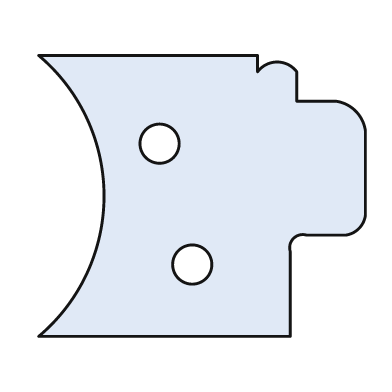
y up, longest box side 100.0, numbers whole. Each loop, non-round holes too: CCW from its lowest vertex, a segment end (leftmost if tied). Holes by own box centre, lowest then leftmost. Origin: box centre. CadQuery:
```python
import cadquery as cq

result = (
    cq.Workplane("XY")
    .moveTo(-50.0, -43.0)
    .lineTo(27.0, -43.0)
    .lineTo(27.0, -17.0)
    .threePointArc((28.0, -13.0), (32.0, -12.0))
    .lineTo(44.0, -12.0)
    .threePointArc((48.0, -10.0), (50.0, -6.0))
    .lineTo(50.0, 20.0)
    .threePointArc((47.0, 26.0), (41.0, 29.0))
    .lineTo(29.0, 29.0)
    .lineTo(29.0, 38.0)
    .threePointArc((23.0, 41.0), (17.0, 38.0))
    .lineTo(17.0, 43.0)
    .lineTo(-50.0, 43.0)
    .threePointArc((-30.0, 0.0), (-50.0, -43.0))
    .close()
    .moveTo(-3.0, -21.0)
    .circle(6.0)
    .moveTo(-13.0, 16.0)
    .circle(6.0)
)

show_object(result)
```